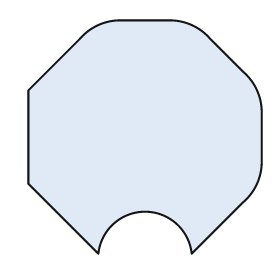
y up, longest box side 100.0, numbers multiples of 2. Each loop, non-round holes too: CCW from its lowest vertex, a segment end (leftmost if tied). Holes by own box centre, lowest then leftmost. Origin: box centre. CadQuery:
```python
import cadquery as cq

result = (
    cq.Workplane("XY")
    .moveTo(-20.0, -50.0)
    .threePointArc((0.0, -32.0), (20.0, -50.0))
    .lineTo(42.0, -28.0)
    .threePointArc((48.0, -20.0), (50.0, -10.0))
    .lineTo(50.0, 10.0)
    .threePointArc((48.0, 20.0), (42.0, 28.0))
    .lineTo(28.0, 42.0)
    .threePointArc((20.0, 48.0), (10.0, 50.0))
    .lineTo(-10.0, 50.0)
    .threePointArc((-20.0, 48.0), (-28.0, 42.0))
    .lineTo(-50.0, 20.0)
    .lineTo(-50.0, -20.0)
    .close()
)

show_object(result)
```